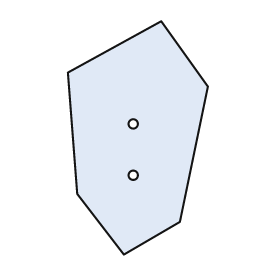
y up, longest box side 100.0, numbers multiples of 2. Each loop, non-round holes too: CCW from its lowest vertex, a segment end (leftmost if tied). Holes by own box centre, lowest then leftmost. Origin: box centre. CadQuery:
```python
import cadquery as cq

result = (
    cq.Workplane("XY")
    .moveTo(-6.0, -50.0)
    .lineTo(18.0, -36.0)
    .lineTo(30.0, 22.0)
    .lineTo(10.0, 50.0)
    .lineTo(-30.0, 28.0)
    .lineTo(-26.0, -24.0)
    .close()
    .moveTo(-2.0, -16.0)
    .circle(2.0)
    .moveTo(-2.0, 6.0)
    .circle(2.0)
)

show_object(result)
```